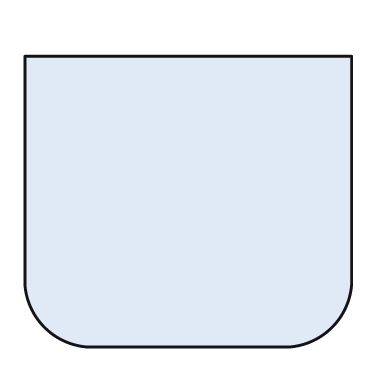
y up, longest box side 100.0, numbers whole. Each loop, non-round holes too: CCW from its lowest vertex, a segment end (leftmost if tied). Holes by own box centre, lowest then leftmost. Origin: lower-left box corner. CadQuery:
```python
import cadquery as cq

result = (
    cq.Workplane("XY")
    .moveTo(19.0, 0.0)
    .lineTo(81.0, 0.0)
    .threePointArc((94.0, 6.0), (100.0, 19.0))
    .lineTo(100.0, 89.0)
    .lineTo(0.0, 89.0)
    .lineTo(0.0, 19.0)
    .threePointArc((6.0, 6.0), (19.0, 0.0))
    .close()
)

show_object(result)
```